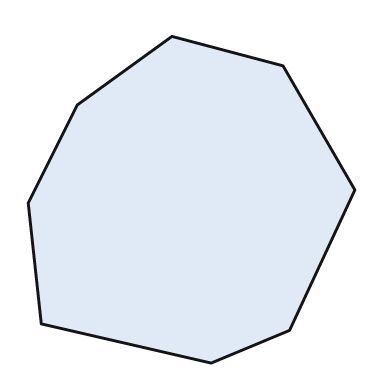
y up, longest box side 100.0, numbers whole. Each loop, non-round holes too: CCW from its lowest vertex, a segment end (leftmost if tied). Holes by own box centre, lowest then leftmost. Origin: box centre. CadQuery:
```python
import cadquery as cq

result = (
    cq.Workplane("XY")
    .moveTo(6.0, -50.0)
    .lineTo(30.0, -40.0)
    .lineTo(50.0, 3.0)
    .lineTo(28.0, 41.0)
    .lineTo(-6.0, 50.0)
    .lineTo(-35.0, 29.0)
    .lineTo(-50.0, -1.0)
    .lineTo(-46.0, -38.0)
    .close()
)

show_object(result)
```